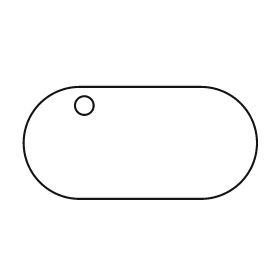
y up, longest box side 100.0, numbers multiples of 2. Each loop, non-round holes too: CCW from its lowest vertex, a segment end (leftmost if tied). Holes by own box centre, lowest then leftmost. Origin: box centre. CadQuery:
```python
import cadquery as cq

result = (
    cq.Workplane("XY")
    .moveTo(-26.0, -24.0)
    .lineTo(26.0, -24.0)
    .threePointArc((50.0, 0.0), (26.0, 24.0))
    .lineTo(-26.0, 24.0)
    .threePointArc((-50.0, 0.0), (-26.0, -24.0))
    .close()
    .moveTo(-24.0, 16.0)
    .circle(4.0)
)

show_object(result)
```